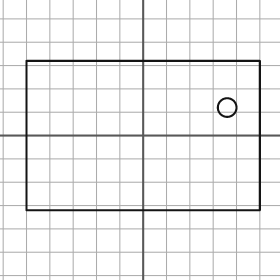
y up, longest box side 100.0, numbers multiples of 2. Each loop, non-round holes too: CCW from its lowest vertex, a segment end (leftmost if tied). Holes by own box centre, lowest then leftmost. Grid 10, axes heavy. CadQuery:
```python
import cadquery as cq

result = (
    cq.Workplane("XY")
    .moveTo(-50.0, -32.0)
    .lineTo(50.0, -32.0)
    .lineTo(50.0, 32.0)
    .lineTo(-50.0, 32.0)
    .close()
    .moveTo(36.0, 12.0)
    .circle(4.0)
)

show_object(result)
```